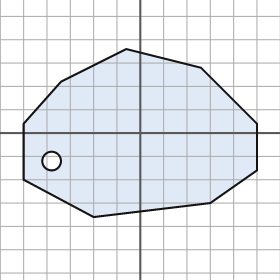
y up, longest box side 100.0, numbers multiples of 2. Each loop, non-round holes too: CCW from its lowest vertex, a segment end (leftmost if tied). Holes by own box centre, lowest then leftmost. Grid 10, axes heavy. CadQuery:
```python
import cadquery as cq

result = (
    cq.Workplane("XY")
    .moveTo(-20.0, -36.0)
    .lineTo(30.0, -30.0)
    .lineTo(50.0, -16.0)
    .lineTo(50.0, 4.0)
    .lineTo(26.0, 28.0)
    .lineTo(-6.0, 36.0)
    .lineTo(-34.0, 22.0)
    .lineTo(-50.0, 4.0)
    .lineTo(-50.0, -20.0)
    .close()
    .moveTo(-38.0, -12.0)
    .circle(4.0)
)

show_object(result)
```